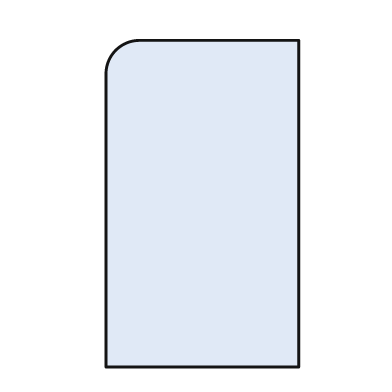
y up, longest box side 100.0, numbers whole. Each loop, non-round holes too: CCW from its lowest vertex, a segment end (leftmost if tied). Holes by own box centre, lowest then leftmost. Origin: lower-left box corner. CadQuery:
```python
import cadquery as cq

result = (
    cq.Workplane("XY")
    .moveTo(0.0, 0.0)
    .lineTo(59.0, 0.0)
    .lineTo(59.0, 100.0)
    .lineTo(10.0, 100.0)
    .threePointArc((3.0, 97.0), (0.0, 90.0))
    .close()
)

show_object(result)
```